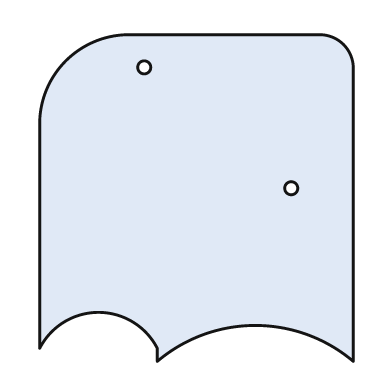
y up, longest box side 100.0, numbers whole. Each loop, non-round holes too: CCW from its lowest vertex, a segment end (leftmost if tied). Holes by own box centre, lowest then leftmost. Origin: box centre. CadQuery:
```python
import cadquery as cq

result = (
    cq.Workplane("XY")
    .moveTo(-12.0, -50.0)
    .threePointArc((18.0, -39.0), (48.0, -50.0))
    .lineTo(48.0, 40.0)
    .threePointArc((45.0, 47.0), (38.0, 50.0))
    .lineTo(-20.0, 50.0)
    .threePointArc((-40.0, 42.0), (-48.0, 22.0))
    .lineTo(-48.0, -46.0)
    .threePointArc((-30.0, -35.0), (-12.0, -46.0))
    .close()
    .moveTo(29.0, 3.0)
    .circle(2.0)
    .moveTo(-16.0, 40.0)
    .circle(2.0)
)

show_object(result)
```